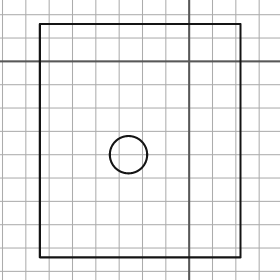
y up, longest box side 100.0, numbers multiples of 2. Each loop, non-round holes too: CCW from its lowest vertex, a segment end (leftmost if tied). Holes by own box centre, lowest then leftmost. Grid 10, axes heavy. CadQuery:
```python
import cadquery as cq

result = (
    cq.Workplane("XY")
    .moveTo(-64.0, -84.0)
    .lineTo(22.0, -84.0)
    .lineTo(22.0, 16.0)
    .lineTo(-64.0, 16.0)
    .close()
    .moveTo(-26.0, -40.0)
    .circle(8.0)
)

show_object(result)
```